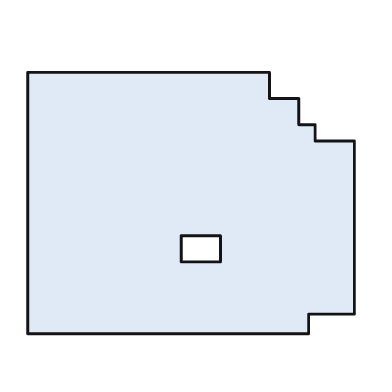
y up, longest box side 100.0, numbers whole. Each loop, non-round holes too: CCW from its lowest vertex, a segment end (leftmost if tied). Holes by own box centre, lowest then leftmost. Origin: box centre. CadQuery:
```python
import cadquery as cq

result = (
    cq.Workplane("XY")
    .moveTo(-50.0, -40.0)
    .lineTo(36.0, -40.0)
    .lineTo(36.0, -34.0)
    .lineTo(50.0, -34.0)
    .lineTo(50.0, 19.0)
    .lineTo(38.0, 19.0)
    .lineTo(38.0, 24.0)
    .lineTo(33.0, 24.0)
    .lineTo(33.0, 32.0)
    .lineTo(24.0, 32.0)
    .lineTo(24.0, 40.0)
    .lineTo(-50.0, 40.0)
    .close()
    .moveTo(-3.0, -18.0)
    .lineTo(9.0, -18.0)
    .lineTo(9.0, -10.0)
    .lineTo(-3.0, -10.0)
    .close()
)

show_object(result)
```